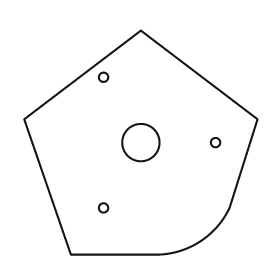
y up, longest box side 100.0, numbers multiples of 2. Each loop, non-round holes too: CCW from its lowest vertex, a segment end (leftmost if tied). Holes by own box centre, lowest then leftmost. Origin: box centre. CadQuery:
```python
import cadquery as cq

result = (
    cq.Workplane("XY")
    .moveTo(-30.0, -48.0)
    .lineTo(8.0, -48.0)
    .threePointArc((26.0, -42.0), (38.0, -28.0))
    .lineTo(50.0, 10.0)
    .lineTo(0.0, 48.0)
    .lineTo(-50.0, 10.0)
    .close()
    .moveTo(-16.0, -28.0)
    .circle(2.0)
    .moveTo(0.0, 0.0)
    .circle(8.0)
    .moveTo(32.0, 0.0)
    .circle(2.0)
    .moveTo(-16.0, 28.0)
    .circle(2.0)
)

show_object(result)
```